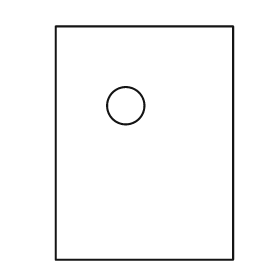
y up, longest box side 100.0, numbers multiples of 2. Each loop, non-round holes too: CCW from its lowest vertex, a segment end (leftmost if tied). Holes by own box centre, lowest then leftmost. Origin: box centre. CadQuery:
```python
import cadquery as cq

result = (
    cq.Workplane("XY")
    .moveTo(-38.0, -50.0)
    .lineTo(38.0, -50.0)
    .lineTo(38.0, 50.0)
    .lineTo(-38.0, 50.0)
    .close()
    .moveTo(-8.0, 16.0)
    .circle(8.0)
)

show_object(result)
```